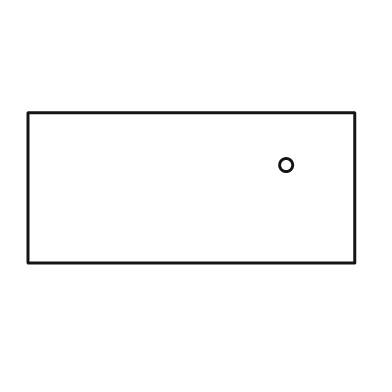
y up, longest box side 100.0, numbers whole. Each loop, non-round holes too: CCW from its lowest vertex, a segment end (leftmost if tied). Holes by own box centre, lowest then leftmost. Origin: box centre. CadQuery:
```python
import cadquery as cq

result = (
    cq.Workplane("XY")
    .moveTo(-50.0, -23.0)
    .lineTo(50.0, -23.0)
    .lineTo(50.0, 23.0)
    .lineTo(-50.0, 23.0)
    .close()
    .moveTo(29.0, 7.0)
    .circle(2.0)
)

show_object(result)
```